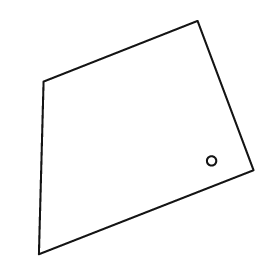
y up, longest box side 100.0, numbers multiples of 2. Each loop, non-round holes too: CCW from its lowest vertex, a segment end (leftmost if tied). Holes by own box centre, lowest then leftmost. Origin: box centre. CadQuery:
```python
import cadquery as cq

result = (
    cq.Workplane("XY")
    .moveTo(-46.0, -50.0)
    .lineTo(46.0, -14.0)
    .lineTo(22.0, 50.0)
    .lineTo(-44.0, 24.0)
    .close()
    .moveTo(28.0, -10.0)
    .circle(2.0)
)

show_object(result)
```